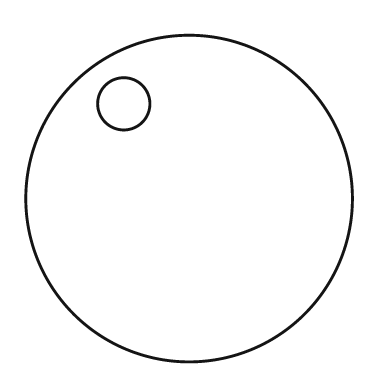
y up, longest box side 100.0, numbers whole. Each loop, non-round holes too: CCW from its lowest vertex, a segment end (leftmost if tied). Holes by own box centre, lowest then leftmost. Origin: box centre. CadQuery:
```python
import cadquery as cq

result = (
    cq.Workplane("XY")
    .moveTo(0.0, 0.0)
    .circle(50.0)
    .moveTo(-20.0, 29.0)
    .circle(8.0)
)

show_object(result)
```